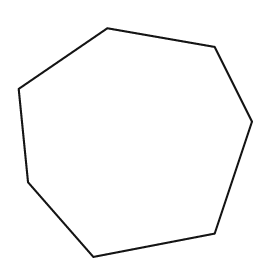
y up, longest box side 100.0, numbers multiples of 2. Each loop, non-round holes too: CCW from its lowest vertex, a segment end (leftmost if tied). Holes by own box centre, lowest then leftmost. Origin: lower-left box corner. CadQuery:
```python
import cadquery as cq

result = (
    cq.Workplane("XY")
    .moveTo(32.0, 0.0)
    .lineTo(84.0, 10.0)
    .lineTo(100.0, 58.0)
    .lineTo(84.0, 90.0)
    .lineTo(38.0, 98.0)
    .lineTo(0.0, 72.0)
    .lineTo(4.0, 32.0)
    .close()
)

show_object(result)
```